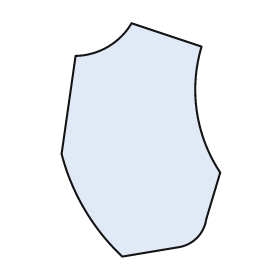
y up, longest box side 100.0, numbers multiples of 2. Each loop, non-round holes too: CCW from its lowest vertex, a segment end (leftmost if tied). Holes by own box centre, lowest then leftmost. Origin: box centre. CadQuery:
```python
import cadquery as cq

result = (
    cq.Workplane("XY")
    .moveTo(-8.0, -50.0)
    .lineTo(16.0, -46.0)
    .threePointArc((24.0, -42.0), (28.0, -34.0))
    .lineTo(34.0, -14.0)
    .threePointArc((24.0, 12.0), (26.0, 40.0))
    .lineTo(-4.0, 50.0)
    .threePointArc((-14.0, 40.0), (-28.0, 36.0))
    .lineTo(-34.0, -6.0)
    .threePointArc((-24.0, -30.0), (-8.0, -50.0))
    .close()
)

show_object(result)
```